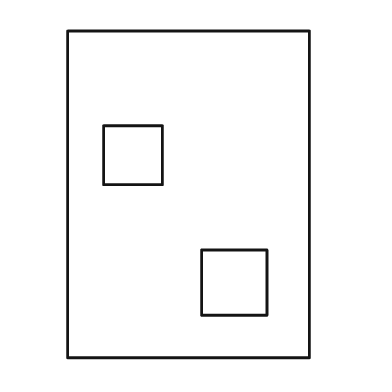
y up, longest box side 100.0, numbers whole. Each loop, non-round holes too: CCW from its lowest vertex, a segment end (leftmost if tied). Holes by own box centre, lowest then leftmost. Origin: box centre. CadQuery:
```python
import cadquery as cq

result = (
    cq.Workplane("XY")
    .moveTo(-37.0, -50.0)
    .lineTo(37.0, -50.0)
    .lineTo(37.0, 50.0)
    .lineTo(-37.0, 50.0)
    .close()
    .moveTo(4.0, -37.0)
    .lineTo(24.0, -37.0)
    .lineTo(24.0, -17.0)
    .lineTo(4.0, -17.0)
    .close()
    .moveTo(-26.0, 3.0)
    .lineTo(-8.0, 3.0)
    .lineTo(-8.0, 21.0)
    .lineTo(-26.0, 21.0)
    .close()
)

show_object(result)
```